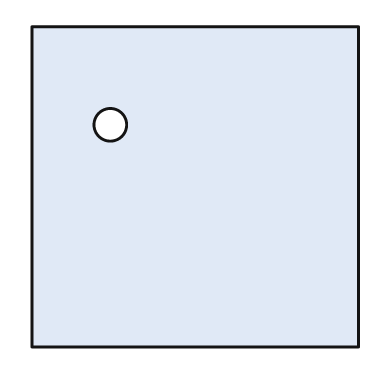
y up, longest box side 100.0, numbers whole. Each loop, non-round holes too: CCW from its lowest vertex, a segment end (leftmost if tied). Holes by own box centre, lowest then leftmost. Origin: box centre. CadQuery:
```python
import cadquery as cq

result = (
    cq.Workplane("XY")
    .moveTo(-50.0, -49.0)
    .lineTo(50.0, -49.0)
    .lineTo(50.0, 49.0)
    .lineTo(-50.0, 49.0)
    .close()
    .moveTo(-26.0, 19.0)
    .circle(5.0)
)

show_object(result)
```